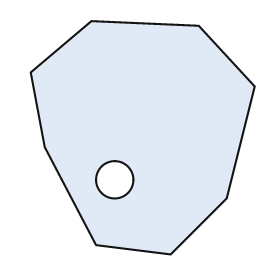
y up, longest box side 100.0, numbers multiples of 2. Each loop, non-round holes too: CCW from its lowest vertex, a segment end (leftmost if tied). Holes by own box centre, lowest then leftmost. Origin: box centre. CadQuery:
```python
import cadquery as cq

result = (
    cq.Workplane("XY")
    .moveTo(12.0, -50.0)
    .lineTo(36.0, -26.0)
    .lineTo(48.0, 22.0)
    .lineTo(24.0, 48.0)
    .lineTo(-22.0, 50.0)
    .lineTo(-48.0, 28.0)
    .lineTo(-42.0, -4.0)
    .lineTo(-20.0, -46.0)
    .close()
    .moveTo(-12.0, -18.0)
    .circle(8.0)
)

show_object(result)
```